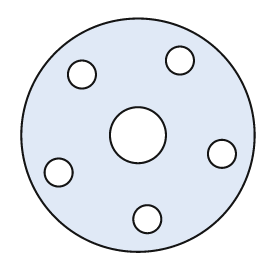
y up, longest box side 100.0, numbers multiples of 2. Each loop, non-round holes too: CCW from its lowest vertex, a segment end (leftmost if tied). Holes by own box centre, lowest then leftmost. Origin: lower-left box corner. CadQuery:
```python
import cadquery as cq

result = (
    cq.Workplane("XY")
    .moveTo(50.0, 50.0)
    .circle(50.0)
    .moveTo(54.0, 14.0)
    .circle(6.0)
    .moveTo(16.0, 34.0)
    .circle(6.0)
    .moveTo(86.0, 42.0)
    .circle(6.0)
    .moveTo(50.0, 50.0)
    .circle(12.0)
    .moveTo(26.0, 76.0)
    .circle(6.0)
    .moveTo(68.0, 82.0)
    .circle(6.0)
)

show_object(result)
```